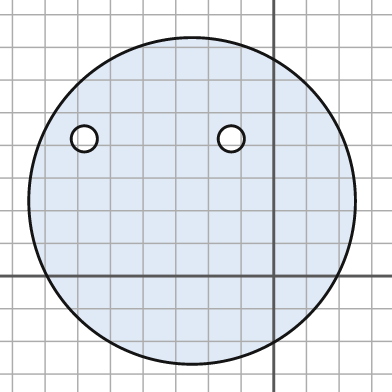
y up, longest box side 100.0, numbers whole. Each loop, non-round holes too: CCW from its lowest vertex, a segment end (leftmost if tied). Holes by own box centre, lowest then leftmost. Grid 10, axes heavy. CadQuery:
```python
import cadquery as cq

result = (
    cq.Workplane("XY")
    .moveTo(-25.0, 23.0)
    .circle(50.0)
    .moveTo(-58.0, 42.0)
    .circle(4.0)
    .moveTo(-13.0, 42.0)
    .circle(4.0)
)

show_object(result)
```